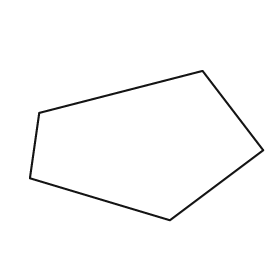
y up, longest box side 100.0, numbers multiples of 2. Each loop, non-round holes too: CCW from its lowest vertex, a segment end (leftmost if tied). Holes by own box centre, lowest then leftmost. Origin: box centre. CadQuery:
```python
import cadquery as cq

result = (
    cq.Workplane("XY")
    .moveTo(10.0, -32.0)
    .lineTo(50.0, -2.0)
    .lineTo(24.0, 32.0)
    .lineTo(-46.0, 14.0)
    .lineTo(-50.0, -14.0)
    .close()
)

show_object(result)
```